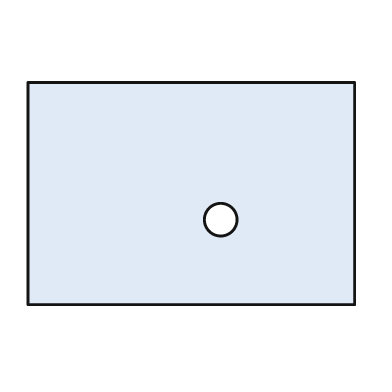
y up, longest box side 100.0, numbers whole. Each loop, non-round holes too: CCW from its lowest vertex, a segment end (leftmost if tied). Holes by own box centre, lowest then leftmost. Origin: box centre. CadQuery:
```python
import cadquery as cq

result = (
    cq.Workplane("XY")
    .moveTo(-50.0, -34.0)
    .lineTo(50.0, -34.0)
    .lineTo(50.0, 34.0)
    .lineTo(-50.0, 34.0)
    .close()
    .moveTo(9.0, -8.0)
    .circle(5.0)
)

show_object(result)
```